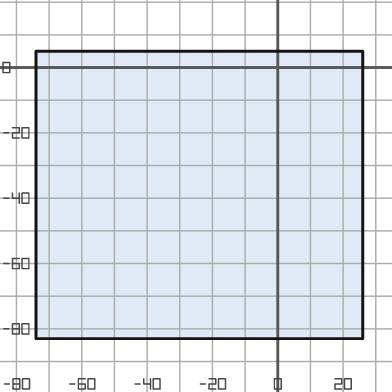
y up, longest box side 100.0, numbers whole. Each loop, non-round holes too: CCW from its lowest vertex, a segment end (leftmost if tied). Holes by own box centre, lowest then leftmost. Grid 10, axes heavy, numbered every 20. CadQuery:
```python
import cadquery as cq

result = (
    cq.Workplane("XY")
    .moveTo(-74.0, -83.0)
    .lineTo(26.0, -83.0)
    .lineTo(26.0, 5.0)
    .lineTo(-74.0, 5.0)
    .close()
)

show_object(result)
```